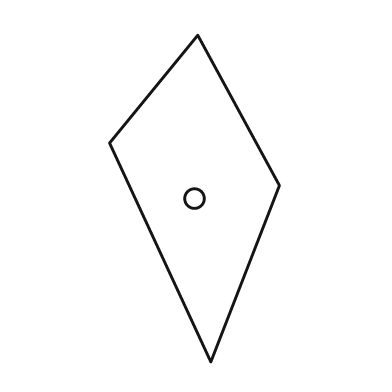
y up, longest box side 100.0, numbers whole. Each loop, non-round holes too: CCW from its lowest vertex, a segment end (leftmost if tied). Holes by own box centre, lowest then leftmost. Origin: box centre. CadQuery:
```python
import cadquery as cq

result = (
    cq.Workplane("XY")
    .moveTo(5.0, -50.0)
    .lineTo(26.0, 4.0)
    .lineTo(1.0, 50.0)
    .lineTo(-26.0, 17.0)
    .close()
    .moveTo(0.0, 0.0)
    .circle(3.0)
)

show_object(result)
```